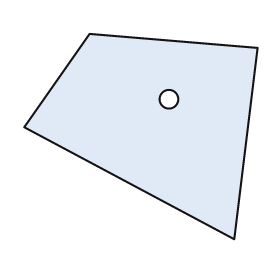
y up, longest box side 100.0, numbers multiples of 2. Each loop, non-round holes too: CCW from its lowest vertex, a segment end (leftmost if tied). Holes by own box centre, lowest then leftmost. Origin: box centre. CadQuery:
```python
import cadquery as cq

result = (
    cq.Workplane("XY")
    .moveTo(40.0, -44.0)
    .lineTo(50.0, 38.0)
    .lineTo(-22.0, 44.0)
    .lineTo(-50.0, 4.0)
    .close()
    .moveTo(12.0, 16.0)
    .circle(4.0)
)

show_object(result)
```